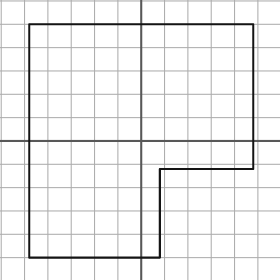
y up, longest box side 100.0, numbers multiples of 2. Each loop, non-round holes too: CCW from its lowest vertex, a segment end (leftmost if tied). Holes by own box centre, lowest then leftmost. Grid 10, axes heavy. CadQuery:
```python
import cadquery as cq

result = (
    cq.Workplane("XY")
    .moveTo(-48.0, -50.0)
    .lineTo(8.0, -50.0)
    .lineTo(8.0, -12.0)
    .lineTo(48.0, -12.0)
    .lineTo(48.0, 50.0)
    .lineTo(-48.0, 50.0)
    .close()
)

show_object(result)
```